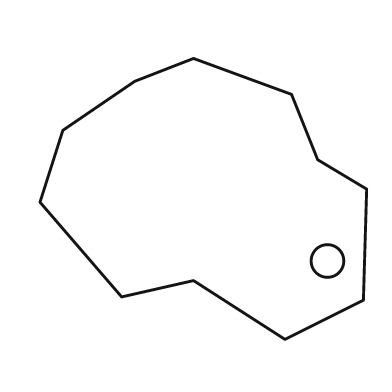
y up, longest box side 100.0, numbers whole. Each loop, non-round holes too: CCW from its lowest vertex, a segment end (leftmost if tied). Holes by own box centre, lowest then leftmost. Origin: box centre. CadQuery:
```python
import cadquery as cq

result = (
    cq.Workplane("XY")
    .moveTo(25.0, -43.0)
    .lineTo(49.0, -31.0)
    .lineTo(50.0, 3.0)
    .lineTo(35.0, 12.0)
    .lineTo(27.0, 32.0)
    .lineTo(-3.0, 43.0)
    .lineTo(-21.0, 36.0)
    .lineTo(-43.0, 21.0)
    .lineTo(-50.0, -1.0)
    .lineTo(-25.0, -30.0)
    .lineTo(-3.0, -25.0)
    .close()
    .moveTo(38.0, -19.0)
    .circle(5.0)
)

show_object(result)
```